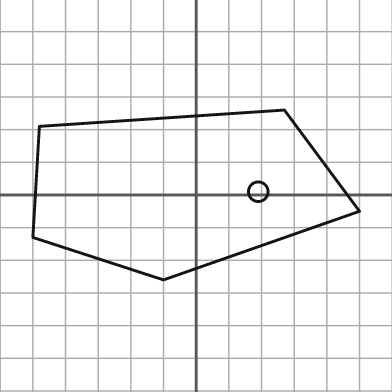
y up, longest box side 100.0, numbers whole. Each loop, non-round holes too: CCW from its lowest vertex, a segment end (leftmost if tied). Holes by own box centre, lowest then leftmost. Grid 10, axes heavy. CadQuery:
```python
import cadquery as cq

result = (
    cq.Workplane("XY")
    .moveTo(-10.0, -26.0)
    .lineTo(50.0, -5.0)
    .lineTo(27.0, 26.0)
    .lineTo(-48.0, 21.0)
    .lineTo(-50.0, -13.0)
    .close()
    .moveTo(19.0, 1.0)
    .circle(3.0)
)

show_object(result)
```